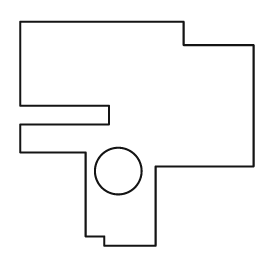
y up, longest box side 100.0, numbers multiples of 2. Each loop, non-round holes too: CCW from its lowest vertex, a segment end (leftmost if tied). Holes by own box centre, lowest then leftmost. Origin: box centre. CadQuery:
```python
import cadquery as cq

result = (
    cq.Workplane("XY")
    .moveTo(-14.0, -48.0)
    .lineTo(8.0, -48.0)
    .lineTo(8.0, -14.0)
    .lineTo(50.0, -14.0)
    .lineTo(50.0, 38.0)
    .lineTo(20.0, 38.0)
    .lineTo(20.0, 48.0)
    .lineTo(-50.0, 48.0)
    .lineTo(-50.0, 12.0)
    .lineTo(-12.0, 12.0)
    .lineTo(-12.0, 4.0)
    .lineTo(-50.0, 4.0)
    .lineTo(-50.0, -8.0)
    .lineTo(-22.0, -8.0)
    .lineTo(-22.0, -44.0)
    .lineTo(-14.0, -44.0)
    .close()
    .moveTo(-8.0, -16.0)
    .circle(10.0)
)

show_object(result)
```